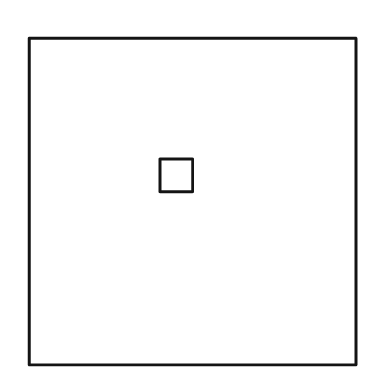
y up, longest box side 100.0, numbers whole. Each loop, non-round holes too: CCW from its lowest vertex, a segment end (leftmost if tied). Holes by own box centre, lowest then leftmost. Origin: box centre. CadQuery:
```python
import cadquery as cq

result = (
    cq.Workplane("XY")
    .moveTo(-50.0, -50.0)
    .lineTo(50.0, -50.0)
    .lineTo(50.0, 50.0)
    .lineTo(-50.0, 50.0)
    .close()
    .moveTo(-10.0, 3.0)
    .lineTo(0.0, 3.0)
    .lineTo(0.0, 13.0)
    .lineTo(-10.0, 13.0)
    .close()
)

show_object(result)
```